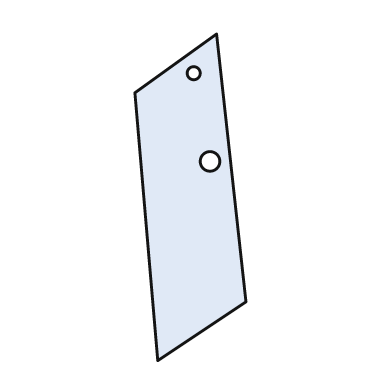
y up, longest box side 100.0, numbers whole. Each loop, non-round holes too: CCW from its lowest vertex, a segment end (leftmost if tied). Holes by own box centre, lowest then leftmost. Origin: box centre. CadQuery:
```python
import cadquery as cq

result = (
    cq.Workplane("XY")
    .moveTo(-10.0, -50.0)
    .lineTo(17.0, -32.0)
    .lineTo(8.0, 50.0)
    .lineTo(-17.0, 32.0)
    .close()
    .moveTo(6.0, 11.0)
    .circle(3.0)
    .moveTo(1.0, 38.0)
    .circle(2.0)
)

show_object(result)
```